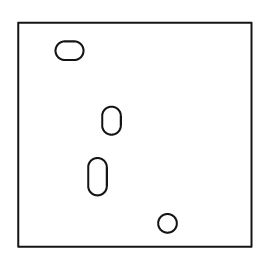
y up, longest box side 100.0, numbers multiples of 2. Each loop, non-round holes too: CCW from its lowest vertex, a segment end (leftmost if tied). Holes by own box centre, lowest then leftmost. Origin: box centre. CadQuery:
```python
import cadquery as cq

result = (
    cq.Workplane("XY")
    .moveTo(-50.0, -48.0)
    .lineTo(50.0, -48.0)
    .lineTo(50.0, 48.0)
    .lineTo(-50.0, 48.0)
    .close()
    .moveTo(14.0, -38.0)
    .circle(4.0)
    .moveTo(-20.0, -22.0)
    .threePointArc((-16.0, -26.0), (-12.0, -22.0))
    .lineTo(-12.0, -14.0)
    .threePointArc((-16.0, -10.0), (-20.0, -14.0))
    .close()
    .moveTo(-14.0, 4.0)
    .threePointArc((-10.0, 0.0), (-6.0, 4.0))
    .lineTo(-6.0, 8.0)
    .threePointArc((-10.0, 12.0), (-14.0, 8.0))
    .close()
    .moveTo(-30.0, 32.0)
    .lineTo(-26.0, 32.0)
    .threePointArc((-22.0, 36.0), (-26.0, 40.0))
    .lineTo(-30.0, 40.0)
    .threePointArc((-34.0, 36.0), (-30.0, 32.0))
    .close()
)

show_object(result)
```